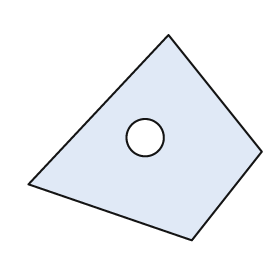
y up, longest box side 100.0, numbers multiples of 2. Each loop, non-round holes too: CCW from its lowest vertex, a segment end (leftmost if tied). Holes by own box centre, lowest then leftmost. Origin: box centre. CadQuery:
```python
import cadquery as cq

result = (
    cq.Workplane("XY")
    .moveTo(20.0, -44.0)
    .lineTo(50.0, -6.0)
    .lineTo(10.0, 44.0)
    .lineTo(-50.0, -20.0)
    .close()
    .moveTo(0.0, 0.0)
    .circle(8.0)
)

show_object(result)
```